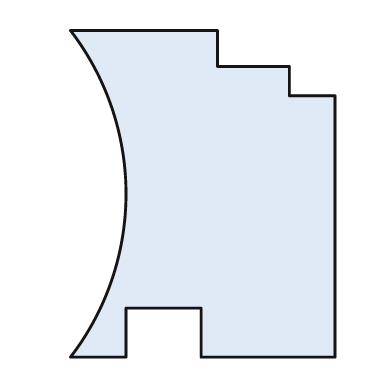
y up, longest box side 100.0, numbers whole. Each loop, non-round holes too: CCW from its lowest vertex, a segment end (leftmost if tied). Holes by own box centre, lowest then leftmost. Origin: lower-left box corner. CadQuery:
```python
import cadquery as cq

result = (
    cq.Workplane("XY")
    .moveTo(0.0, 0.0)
    .lineTo(17.0, 0.0)
    .lineTo(17.0, 15.0)
    .lineTo(40.0, 15.0)
    .lineTo(40.0, 0.0)
    .lineTo(81.0, 0.0)
    .lineTo(81.0, 80.0)
    .lineTo(67.0, 80.0)
    .lineTo(67.0, 89.0)
    .lineTo(45.0, 89.0)
    .lineTo(45.0, 100.0)
    .lineTo(0.0, 100.0)
    .threePointArc((17.0, 50.0), (0.0, 0.0))
    .close()
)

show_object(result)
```